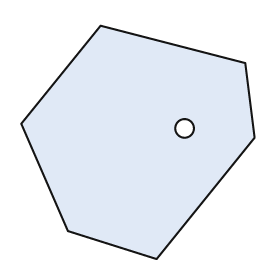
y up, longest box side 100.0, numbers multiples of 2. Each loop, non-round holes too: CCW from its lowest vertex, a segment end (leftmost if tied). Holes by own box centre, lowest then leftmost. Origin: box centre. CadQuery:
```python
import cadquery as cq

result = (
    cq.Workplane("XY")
    .moveTo(8.0, -50.0)
    .lineTo(50.0, 2.0)
    .lineTo(46.0, 34.0)
    .lineTo(-16.0, 50.0)
    .lineTo(-50.0, 8.0)
    .lineTo(-30.0, -38.0)
    .close()
    .moveTo(20.0, 6.0)
    .circle(4.0)
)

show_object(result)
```